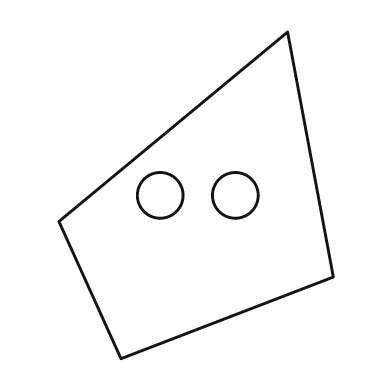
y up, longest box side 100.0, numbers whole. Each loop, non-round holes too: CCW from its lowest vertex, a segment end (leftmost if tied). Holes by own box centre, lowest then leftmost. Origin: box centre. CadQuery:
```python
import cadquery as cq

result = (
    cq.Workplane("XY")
    .moveTo(-23.0, -50.0)
    .lineTo(42.0, -25.0)
    .lineTo(28.0, 50.0)
    .lineTo(-42.0, -8.0)
    .close()
    .moveTo(-11.0, 0.0)
    .circle(7.0)
    .moveTo(12.0, 0.0)
    .circle(7.0)
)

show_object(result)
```